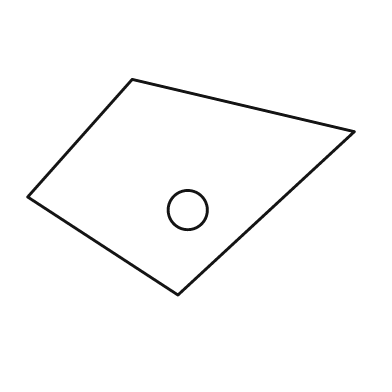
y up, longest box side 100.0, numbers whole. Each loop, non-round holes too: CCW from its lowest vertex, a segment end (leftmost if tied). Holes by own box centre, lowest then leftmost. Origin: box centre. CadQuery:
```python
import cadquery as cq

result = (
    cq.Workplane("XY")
    .moveTo(-4.0, -33.0)
    .lineTo(50.0, 17.0)
    .lineTo(-18.0, 33.0)
    .lineTo(-50.0, -3.0)
    .close()
    .moveTo(-1.0, -7.0)
    .circle(6.0)
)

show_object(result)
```